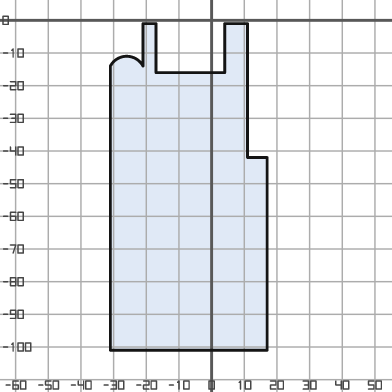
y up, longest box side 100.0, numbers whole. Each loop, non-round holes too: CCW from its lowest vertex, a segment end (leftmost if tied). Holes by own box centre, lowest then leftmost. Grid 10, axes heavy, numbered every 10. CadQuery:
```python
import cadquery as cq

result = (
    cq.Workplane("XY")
    .moveTo(-31.0, -101.0)
    .lineTo(17.0, -101.0)
    .lineTo(17.0, -42.0)
    .lineTo(11.0, -42.0)
    .lineTo(11.0, -1.0)
    .lineTo(4.0, -1.0)
    .lineTo(4.0, -16.0)
    .lineTo(-17.0, -16.0)
    .lineTo(-17.0, -1.0)
    .lineTo(-21.0, -1.0)
    .lineTo(-21.0, -14.0)
    .threePointArc((-26.0, -11.0), (-31.0, -14.0))
    .close()
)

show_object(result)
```